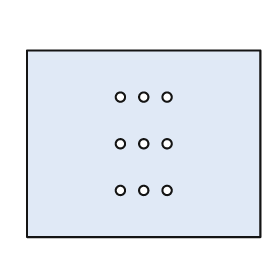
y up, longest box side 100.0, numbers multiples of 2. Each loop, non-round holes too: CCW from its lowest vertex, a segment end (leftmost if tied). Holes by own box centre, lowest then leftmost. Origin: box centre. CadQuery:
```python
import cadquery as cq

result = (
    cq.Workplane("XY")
    .moveTo(-50.0, -40.0)
    .lineTo(50.0, -40.0)
    .lineTo(50.0, 40.0)
    .lineTo(-50.0, 40.0)
    .close()
    .moveTo(-10.0, -20.0)
    .circle(2.0)
    .moveTo(0.0, -20.0)
    .circle(2.0)
    .moveTo(10.0, -20.0)
    .circle(2.0)
    .moveTo(-10.0, 0.0)
    .circle(2.0)
    .moveTo(0.0, 0.0)
    .circle(2.0)
    .moveTo(10.0, 0.0)
    .circle(2.0)
    .moveTo(-10.0, 20.0)
    .circle(2.0)
    .moveTo(0.0, 20.0)
    .circle(2.0)
    .moveTo(10.0, 20.0)
    .circle(2.0)
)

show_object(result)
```